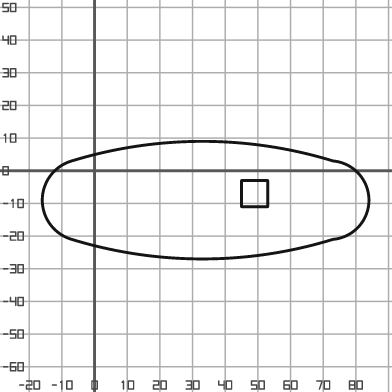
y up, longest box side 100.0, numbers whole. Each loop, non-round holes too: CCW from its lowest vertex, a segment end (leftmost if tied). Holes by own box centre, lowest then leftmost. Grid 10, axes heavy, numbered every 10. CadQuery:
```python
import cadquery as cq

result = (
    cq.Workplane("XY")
    .moveTo(-7.0, -21.0)
    .threePointArc((33.0, -27.0), (73.0, -21.0))
    .threePointArc((84.0, -9.0), (73.0, 3.0))
    .threePointArc((33.0, 9.0), (-7.0, 3.0))
    .threePointArc((-16.0, -9.0), (-7.0, -21.0))
    .close()
    .moveTo(45.0, -11.0)
    .lineTo(53.0, -11.0)
    .lineTo(53.0, -3.0)
    .lineTo(45.0, -3.0)
    .close()
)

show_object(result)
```